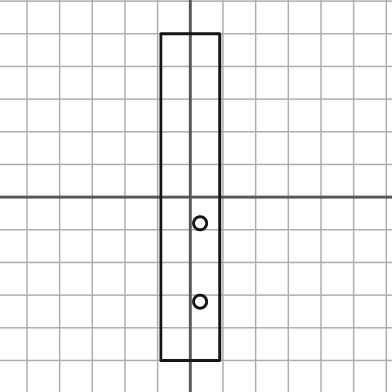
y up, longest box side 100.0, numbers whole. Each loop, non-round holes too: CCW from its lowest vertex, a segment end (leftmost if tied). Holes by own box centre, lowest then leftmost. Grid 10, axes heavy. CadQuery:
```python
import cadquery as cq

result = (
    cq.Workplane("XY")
    .moveTo(-9.0, -50.0)
    .lineTo(9.0, -50.0)
    .lineTo(9.0, 50.0)
    .lineTo(-9.0, 50.0)
    .close()
    .moveTo(3.0, -32.0)
    .circle(2.0)
    .moveTo(3.0, -8.0)
    .circle(2.0)
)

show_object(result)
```